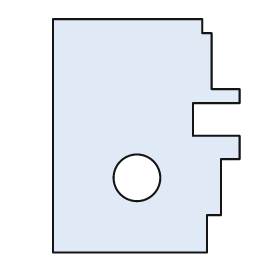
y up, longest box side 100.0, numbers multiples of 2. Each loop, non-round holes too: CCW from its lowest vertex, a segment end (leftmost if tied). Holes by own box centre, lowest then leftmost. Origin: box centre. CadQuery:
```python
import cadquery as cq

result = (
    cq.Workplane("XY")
    .moveTo(-40.0, -50.0)
    .lineTo(26.0, -50.0)
    .lineTo(26.0, -34.0)
    .lineTo(32.0, -34.0)
    .lineTo(32.0, -10.0)
    .lineTo(40.0, -10.0)
    .lineTo(40.0, 0.0)
    .lineTo(20.0, 0.0)
    .lineTo(20.0, 14.0)
    .lineTo(40.0, 14.0)
    .lineTo(40.0, 20.0)
    .lineTo(28.0, 20.0)
    .lineTo(28.0, 44.0)
    .lineTo(24.0, 44.0)
    .lineTo(24.0, 50.0)
    .lineTo(-40.0, 50.0)
    .close()
    .moveTo(-4.0, -18.0)
    .circle(10.0)
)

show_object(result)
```